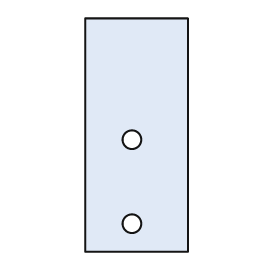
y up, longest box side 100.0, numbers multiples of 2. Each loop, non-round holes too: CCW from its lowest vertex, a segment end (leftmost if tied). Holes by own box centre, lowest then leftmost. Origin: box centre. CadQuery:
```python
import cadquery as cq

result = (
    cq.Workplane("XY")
    .moveTo(-22.0, -50.0)
    .lineTo(22.0, -50.0)
    .lineTo(22.0, 50.0)
    .lineTo(-22.0, 50.0)
    .close()
    .moveTo(-2.0, -38.0)
    .circle(4.0)
    .moveTo(-2.0, -2.0)
    .circle(4.0)
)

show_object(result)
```